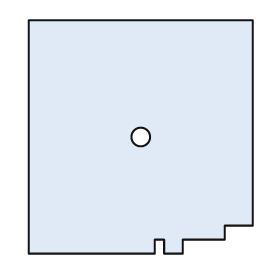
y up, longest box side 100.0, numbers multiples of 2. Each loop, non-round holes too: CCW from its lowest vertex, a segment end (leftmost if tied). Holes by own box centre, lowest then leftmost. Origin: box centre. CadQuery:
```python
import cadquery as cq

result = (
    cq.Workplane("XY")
    .moveTo(-48.0, -50.0)
    .lineTo(6.0, -50.0)
    .lineTo(6.0, -44.0)
    .lineTo(10.0, -44.0)
    .lineTo(10.0, -50.0)
    .lineTo(18.0, -50.0)
    .lineTo(18.0, -44.0)
    .lineTo(36.0, -44.0)
    .lineTo(36.0, -38.0)
    .lineTo(48.0, -38.0)
    .lineTo(48.0, 50.0)
    .lineTo(-48.0, 50.0)
    .close()
    .moveTo(0.0, 0.0)
    .circle(4.0)
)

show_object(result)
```